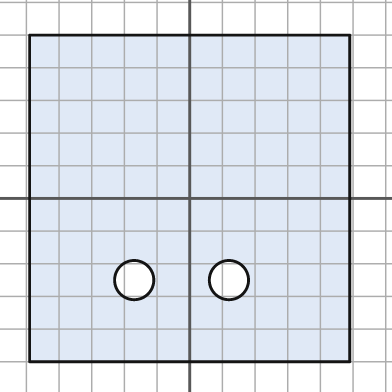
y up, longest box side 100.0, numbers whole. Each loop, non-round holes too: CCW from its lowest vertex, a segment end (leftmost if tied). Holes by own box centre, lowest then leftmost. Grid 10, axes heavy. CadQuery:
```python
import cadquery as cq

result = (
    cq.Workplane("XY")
    .moveTo(-49.0, -50.0)
    .lineTo(49.0, -50.0)
    .lineTo(49.0, 50.0)
    .lineTo(-49.0, 50.0)
    .close()
    .moveTo(-17.0, -25.0)
    .circle(6.0)
    .moveTo(12.0, -25.0)
    .circle(6.0)
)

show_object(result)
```